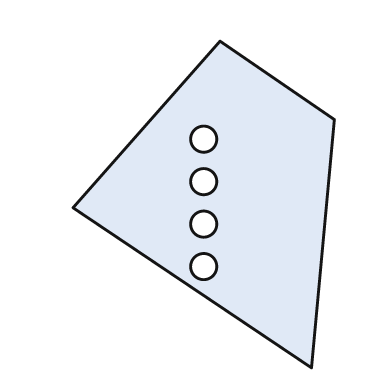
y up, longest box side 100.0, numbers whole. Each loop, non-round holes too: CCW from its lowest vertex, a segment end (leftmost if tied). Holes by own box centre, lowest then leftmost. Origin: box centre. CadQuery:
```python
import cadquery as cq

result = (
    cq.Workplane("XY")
    .moveTo(33.0, -50.0)
    .lineTo(40.0, 26.0)
    .lineTo(5.0, 50.0)
    .lineTo(-40.0, -1.0)
    .close()
    .moveTo(0.0, -19.0)
    .circle(4.0)
    .moveTo(0.0, -6.0)
    .circle(4.0)
    .moveTo(0.0, 7.0)
    .circle(4.0)
    .moveTo(0.0, 20.0)
    .circle(4.0)
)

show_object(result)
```